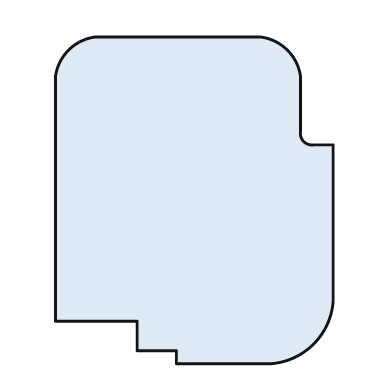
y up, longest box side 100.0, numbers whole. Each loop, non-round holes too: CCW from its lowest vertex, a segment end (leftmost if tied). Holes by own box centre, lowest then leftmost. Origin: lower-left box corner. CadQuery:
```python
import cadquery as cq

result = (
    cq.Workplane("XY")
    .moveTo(37.0, 0.0)
    .lineTo(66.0, 0.0)
    .threePointArc((79.0, 6.0), (85.0, 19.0))
    .lineTo(85.0, 67.0)
    .lineTo(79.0, 67.0)
    .threePointArc((76.0, 68.0), (75.0, 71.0))
    .lineTo(75.0, 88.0)
    .threePointArc((71.0, 96.0), (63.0, 100.0))
    .lineTo(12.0, 100.0)
    .threePointArc((4.0, 96.0), (0.0, 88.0))
    .lineTo(0.0, 13.0)
    .lineTo(25.0, 13.0)
    .lineTo(25.0, 4.0)
    .lineTo(37.0, 4.0)
    .close()
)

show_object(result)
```